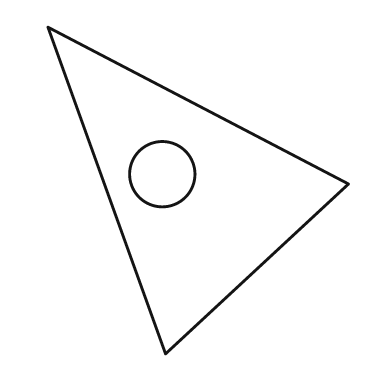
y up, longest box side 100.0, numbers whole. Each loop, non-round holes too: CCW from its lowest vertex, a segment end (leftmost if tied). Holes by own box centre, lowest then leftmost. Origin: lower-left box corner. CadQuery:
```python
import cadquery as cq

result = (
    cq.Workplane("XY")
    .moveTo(36.0, 0.0)
    .lineTo(92.0, 52.0)
    .lineTo(0.0, 100.0)
    .close()
    .moveTo(35.0, 55.0)
    .circle(10.0)
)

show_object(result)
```